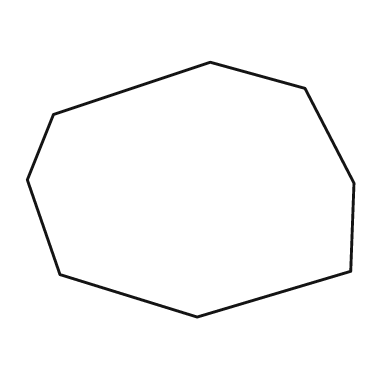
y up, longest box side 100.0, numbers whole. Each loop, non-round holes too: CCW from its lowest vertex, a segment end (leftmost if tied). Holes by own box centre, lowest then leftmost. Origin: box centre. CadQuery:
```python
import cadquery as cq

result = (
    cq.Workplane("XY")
    .moveTo(2.0, -39.0)
    .lineTo(49.0, -25.0)
    .lineTo(50.0, 2.0)
    .lineTo(35.0, 31.0)
    .lineTo(6.0, 39.0)
    .lineTo(-42.0, 23.0)
    .lineTo(-50.0, 3.0)
    .lineTo(-40.0, -26.0)
    .close()
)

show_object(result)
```